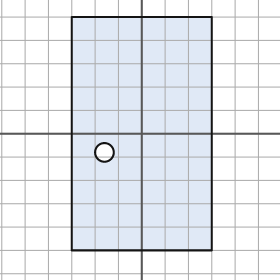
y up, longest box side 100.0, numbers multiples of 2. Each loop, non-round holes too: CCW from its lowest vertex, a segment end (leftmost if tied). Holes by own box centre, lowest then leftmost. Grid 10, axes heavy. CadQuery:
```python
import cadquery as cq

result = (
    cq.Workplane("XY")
    .moveTo(-30.0, -50.0)
    .lineTo(30.0, -50.0)
    .lineTo(30.0, 50.0)
    .lineTo(-30.0, 50.0)
    .close()
    .moveTo(-16.0, -8.0)
    .circle(4.0)
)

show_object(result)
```